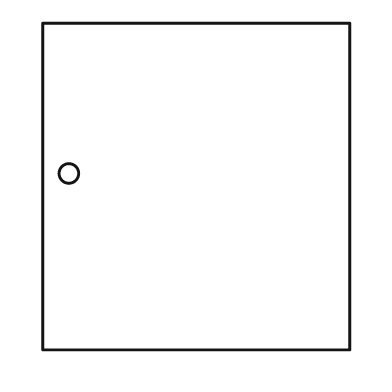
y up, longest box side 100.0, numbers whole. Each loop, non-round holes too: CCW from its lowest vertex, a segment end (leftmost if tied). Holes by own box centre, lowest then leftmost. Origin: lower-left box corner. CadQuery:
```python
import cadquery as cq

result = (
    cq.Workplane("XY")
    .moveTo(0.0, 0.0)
    .lineTo(94.0, 0.0)
    .lineTo(94.0, 100.0)
    .lineTo(0.0, 100.0)
    .close()
    .moveTo(8.0, 54.0)
    .circle(3.0)
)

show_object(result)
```